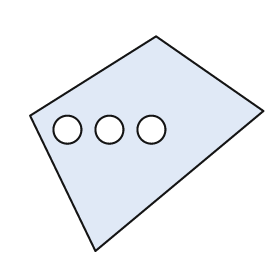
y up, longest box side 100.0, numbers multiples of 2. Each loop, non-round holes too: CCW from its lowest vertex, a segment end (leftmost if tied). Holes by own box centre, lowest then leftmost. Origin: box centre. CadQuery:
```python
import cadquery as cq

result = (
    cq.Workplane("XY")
    .moveTo(-22.0, -46.0)
    .lineTo(50.0, 14.0)
    .lineTo(4.0, 46.0)
    .lineTo(-50.0, 12.0)
    .close()
    .moveTo(-34.0, 6.0)
    .circle(6.0)
    .moveTo(-16.0, 6.0)
    .circle(6.0)
    .moveTo(2.0, 6.0)
    .circle(6.0)
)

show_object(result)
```